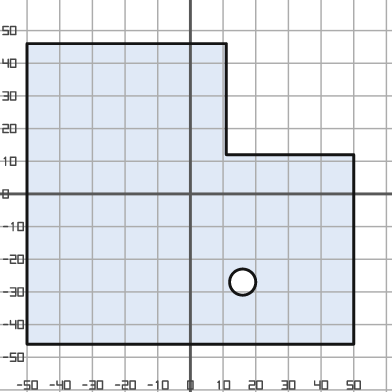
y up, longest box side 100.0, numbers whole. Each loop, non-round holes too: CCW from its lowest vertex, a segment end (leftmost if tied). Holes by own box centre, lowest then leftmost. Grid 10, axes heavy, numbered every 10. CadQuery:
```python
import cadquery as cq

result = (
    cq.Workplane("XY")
    .moveTo(-50.0, -46.0)
    .lineTo(50.0, -46.0)
    .lineTo(50.0, 12.0)
    .lineTo(11.0, 12.0)
    .lineTo(11.0, 46.0)
    .lineTo(-50.0, 46.0)
    .close()
    .moveTo(16.0, -27.0)
    .circle(4.0)
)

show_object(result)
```